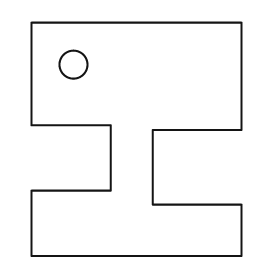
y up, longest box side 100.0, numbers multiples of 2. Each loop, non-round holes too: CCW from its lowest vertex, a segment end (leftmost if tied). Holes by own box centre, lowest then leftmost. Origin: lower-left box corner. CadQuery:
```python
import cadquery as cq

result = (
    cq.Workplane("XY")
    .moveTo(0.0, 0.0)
    .lineTo(90.0, 0.0)
    .lineTo(90.0, 22.0)
    .lineTo(52.0, 22.0)
    .lineTo(52.0, 54.0)
    .lineTo(90.0, 54.0)
    .lineTo(90.0, 100.0)
    .lineTo(0.0, 100.0)
    .lineTo(0.0, 56.0)
    .lineTo(34.0, 56.0)
    .lineTo(34.0, 28.0)
    .lineTo(0.0, 28.0)
    .close()
    .moveTo(18.0, 82.0)
    .circle(6.0)
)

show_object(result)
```